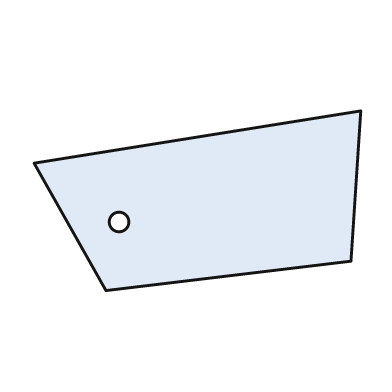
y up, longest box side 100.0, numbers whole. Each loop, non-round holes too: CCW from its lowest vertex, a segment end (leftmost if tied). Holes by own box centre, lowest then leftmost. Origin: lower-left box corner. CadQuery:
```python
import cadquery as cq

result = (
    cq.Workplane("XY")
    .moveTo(22.0, 0.0)
    .lineTo(97.0, 9.0)
    .lineTo(100.0, 55.0)
    .lineTo(0.0, 39.0)
    .close()
    .moveTo(26.0, 21.0)
    .circle(3.0)
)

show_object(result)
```